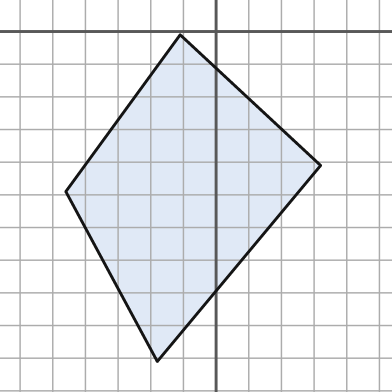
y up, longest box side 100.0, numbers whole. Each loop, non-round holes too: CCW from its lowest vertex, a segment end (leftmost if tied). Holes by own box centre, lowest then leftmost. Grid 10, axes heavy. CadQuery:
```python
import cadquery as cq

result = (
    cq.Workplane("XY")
    .moveTo(-18.0, -101.0)
    .lineTo(32.0, -41.0)
    .lineTo(-11.0, -1.0)
    .lineTo(-46.0, -49.0)
    .close()
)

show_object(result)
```